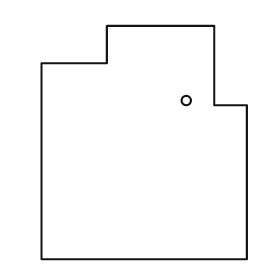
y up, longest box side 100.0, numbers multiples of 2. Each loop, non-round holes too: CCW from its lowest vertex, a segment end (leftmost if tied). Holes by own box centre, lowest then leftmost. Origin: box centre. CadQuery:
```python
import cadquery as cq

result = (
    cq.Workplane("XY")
    .moveTo(-44.0, -50.0)
    .lineTo(44.0, -50.0)
    .lineTo(44.0, 16.0)
    .lineTo(30.0, 16.0)
    .lineTo(30.0, 50.0)
    .lineTo(-16.0, 50.0)
    .lineTo(-16.0, 34.0)
    .lineTo(-44.0, 34.0)
    .close()
    .moveTo(18.0, 18.0)
    .circle(2.0)
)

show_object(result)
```